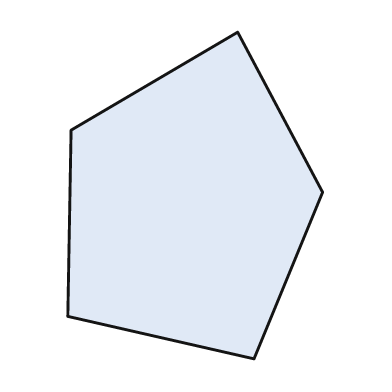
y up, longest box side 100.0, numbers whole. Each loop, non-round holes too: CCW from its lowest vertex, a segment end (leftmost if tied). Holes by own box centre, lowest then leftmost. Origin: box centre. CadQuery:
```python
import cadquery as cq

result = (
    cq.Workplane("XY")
    .moveTo(18.0, -50.0)
    .lineTo(39.0, 1.0)
    .lineTo(13.0, 50.0)
    .lineTo(-38.0, 20.0)
    .lineTo(-39.0, -37.0)
    .close()
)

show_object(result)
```